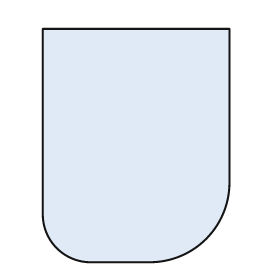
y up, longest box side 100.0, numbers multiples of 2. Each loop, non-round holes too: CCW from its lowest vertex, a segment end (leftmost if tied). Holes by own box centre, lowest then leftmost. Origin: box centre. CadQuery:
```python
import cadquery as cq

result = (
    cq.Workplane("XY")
    .moveTo(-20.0, -50.0)
    .lineTo(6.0, -50.0)
    .threePointArc((30.0, -40.0), (40.0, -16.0))
    .lineTo(40.0, 50.0)
    .lineTo(-40.0, 50.0)
    .lineTo(-40.0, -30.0)
    .threePointArc((-34.0, -44.0), (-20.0, -50.0))
    .close()
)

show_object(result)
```